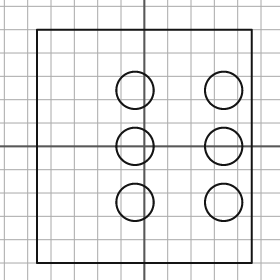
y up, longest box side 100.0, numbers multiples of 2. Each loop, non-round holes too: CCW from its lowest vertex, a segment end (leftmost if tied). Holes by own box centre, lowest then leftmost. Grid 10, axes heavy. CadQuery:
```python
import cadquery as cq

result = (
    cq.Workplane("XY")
    .moveTo(-46.0, -50.0)
    .lineTo(46.0, -50.0)
    .lineTo(46.0, 50.0)
    .lineTo(-46.0, 50.0)
    .close()
    .moveTo(-4.0, -24.0)
    .circle(8.0)
    .moveTo(34.0, -24.0)
    .circle(8.0)
    .moveTo(-4.0, 0.0)
    .circle(8.0)
    .moveTo(34.0, 0.0)
    .circle(8.0)
    .moveTo(-4.0, 24.0)
    .circle(8.0)
    .moveTo(34.0, 24.0)
    .circle(8.0)
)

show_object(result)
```